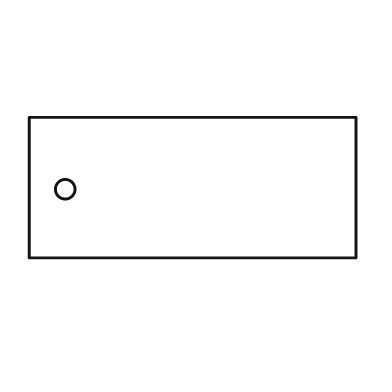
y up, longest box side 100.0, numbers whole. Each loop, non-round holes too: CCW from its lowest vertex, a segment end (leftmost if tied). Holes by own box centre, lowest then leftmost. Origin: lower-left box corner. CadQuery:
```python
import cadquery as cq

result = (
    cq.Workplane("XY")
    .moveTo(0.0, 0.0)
    .lineTo(100.0, 0.0)
    .lineTo(100.0, 43.0)
    .lineTo(0.0, 43.0)
    .close()
    .moveTo(11.0, 21.0)
    .circle(3.0)
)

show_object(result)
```